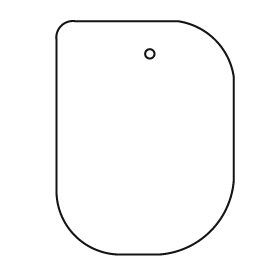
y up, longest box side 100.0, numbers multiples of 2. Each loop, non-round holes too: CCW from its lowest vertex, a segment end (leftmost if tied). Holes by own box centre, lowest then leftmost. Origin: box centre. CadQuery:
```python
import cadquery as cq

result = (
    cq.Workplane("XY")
    .moveTo(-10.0, -50.0)
    .lineTo(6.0, -50.0)
    .threePointArc((28.0, -40.0), (38.0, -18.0))
    .lineTo(38.0, 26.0)
    .threePointArc((30.0, 42.0), (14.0, 50.0))
    .lineTo(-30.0, 50.0)
    .threePointArc((-36.0, 48.0), (-38.0, 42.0))
    .lineTo(-38.0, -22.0)
    .threePointArc((-30.0, -42.0), (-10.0, -50.0))
    .close()
    .moveTo(2.0, 36.0)
    .circle(2.0)
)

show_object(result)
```